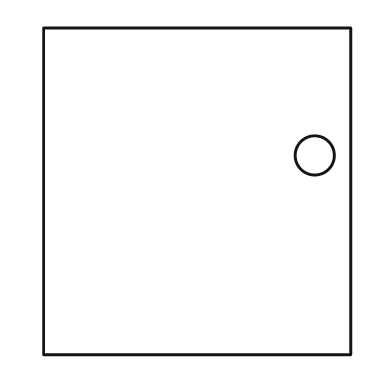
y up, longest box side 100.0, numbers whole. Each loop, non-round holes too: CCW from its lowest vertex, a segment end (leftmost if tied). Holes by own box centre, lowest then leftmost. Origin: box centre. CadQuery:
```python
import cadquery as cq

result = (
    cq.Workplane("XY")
    .moveTo(-47.0, -50.0)
    .lineTo(47.0, -50.0)
    .lineTo(47.0, 50.0)
    .lineTo(-47.0, 50.0)
    .close()
    .moveTo(36.0, 11.0)
    .circle(6.0)
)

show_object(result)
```